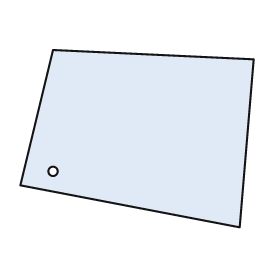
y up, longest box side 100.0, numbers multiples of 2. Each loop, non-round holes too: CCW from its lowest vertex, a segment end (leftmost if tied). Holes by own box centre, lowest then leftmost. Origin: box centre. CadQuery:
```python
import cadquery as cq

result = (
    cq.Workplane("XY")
    .moveTo(44.0, -38.0)
    .lineTo(50.0, 34.0)
    .lineTo(-36.0, 38.0)
    .lineTo(-50.0, -20.0)
    .close()
    .moveTo(-36.0, -14.0)
    .circle(2.0)
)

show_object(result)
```